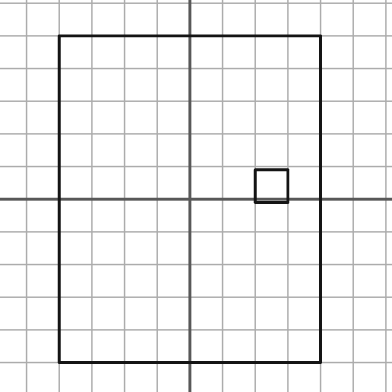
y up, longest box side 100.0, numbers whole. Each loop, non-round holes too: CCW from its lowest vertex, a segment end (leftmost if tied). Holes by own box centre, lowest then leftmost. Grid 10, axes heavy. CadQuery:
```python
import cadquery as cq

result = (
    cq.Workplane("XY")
    .moveTo(-40.0, -50.0)
    .lineTo(40.0, -50.0)
    .lineTo(40.0, 50.0)
    .lineTo(-40.0, 50.0)
    .close()
    .moveTo(20.0, -1.0)
    .lineTo(30.0, -1.0)
    .lineTo(30.0, 9.0)
    .lineTo(20.0, 9.0)
    .close()
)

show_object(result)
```